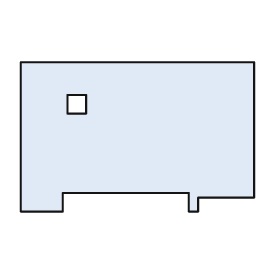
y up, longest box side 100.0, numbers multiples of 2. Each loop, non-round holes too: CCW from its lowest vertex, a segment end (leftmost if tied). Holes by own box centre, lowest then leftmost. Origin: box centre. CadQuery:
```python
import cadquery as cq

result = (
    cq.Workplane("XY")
    .moveTo(-50.0, -32.0)
    .lineTo(-32.0, -32.0)
    .lineTo(-32.0, -24.0)
    .lineTo(22.0, -24.0)
    .lineTo(22.0, -32.0)
    .lineTo(26.0, -32.0)
    .lineTo(26.0, -26.0)
    .lineTo(50.0, -26.0)
    .lineTo(50.0, 32.0)
    .lineTo(-50.0, 32.0)
    .close()
    .moveTo(-30.0, 10.0)
    .lineTo(-22.0, 10.0)
    .lineTo(-22.0, 18.0)
    .lineTo(-30.0, 18.0)
    .close()
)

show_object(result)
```